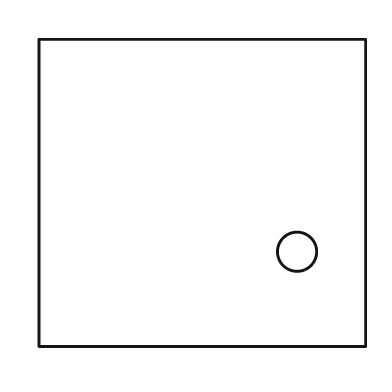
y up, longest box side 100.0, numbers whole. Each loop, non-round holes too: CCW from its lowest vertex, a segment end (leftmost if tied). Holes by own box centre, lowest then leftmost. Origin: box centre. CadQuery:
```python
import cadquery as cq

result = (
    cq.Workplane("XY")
    .moveTo(-50.0, -47.0)
    .lineTo(50.0, -47.0)
    .lineTo(50.0, 47.0)
    .lineTo(-50.0, 47.0)
    .close()
    .moveTo(29.0, -18.0)
    .circle(6.0)
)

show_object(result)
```